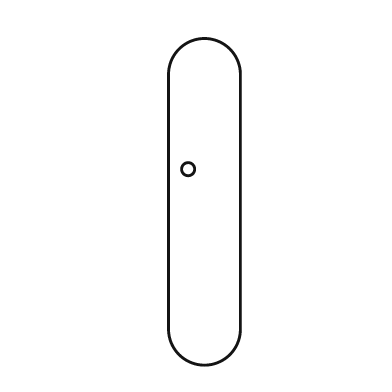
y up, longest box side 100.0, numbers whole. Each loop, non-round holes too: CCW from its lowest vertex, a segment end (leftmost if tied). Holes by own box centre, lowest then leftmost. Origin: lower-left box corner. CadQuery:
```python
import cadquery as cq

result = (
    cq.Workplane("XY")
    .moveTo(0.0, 11.0)
    .threePointArc((11.0, 0.0), (22.0, 11.0))
    .lineTo(22.0, 89.0)
    .threePointArc((11.0, 100.0), (0.0, 89.0))
    .close()
    .moveTo(6.0, 60.0)
    .circle(2.0)
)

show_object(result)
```